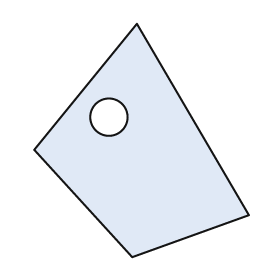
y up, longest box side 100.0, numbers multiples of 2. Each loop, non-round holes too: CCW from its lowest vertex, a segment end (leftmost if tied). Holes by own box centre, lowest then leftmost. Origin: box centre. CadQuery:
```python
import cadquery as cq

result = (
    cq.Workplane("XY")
    .moveTo(-4.0, -50.0)
    .lineTo(46.0, -32.0)
    .lineTo(-2.0, 50.0)
    .lineTo(-46.0, -4.0)
    .close()
    .moveTo(-14.0, 10.0)
    .circle(8.0)
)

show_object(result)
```